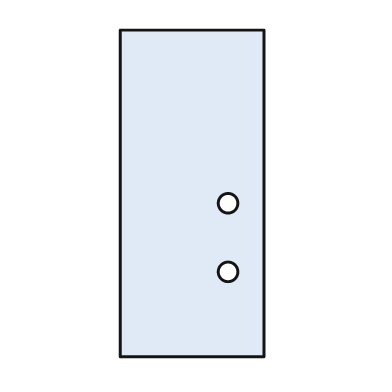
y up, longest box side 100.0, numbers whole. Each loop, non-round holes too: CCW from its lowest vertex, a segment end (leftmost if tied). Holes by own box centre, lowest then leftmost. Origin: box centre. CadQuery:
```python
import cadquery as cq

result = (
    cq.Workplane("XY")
    .moveTo(-22.0, -50.0)
    .lineTo(22.0, -50.0)
    .lineTo(22.0, 50.0)
    .lineTo(-22.0, 50.0)
    .close()
    .moveTo(11.0, -24.0)
    .circle(3.0)
    .moveTo(11.0, -3.0)
    .circle(3.0)
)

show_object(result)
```